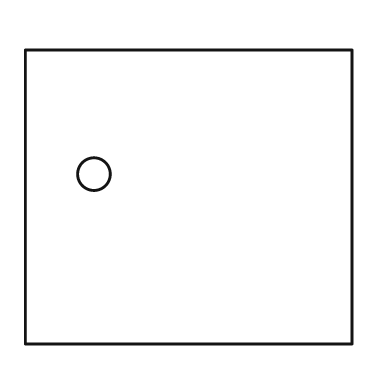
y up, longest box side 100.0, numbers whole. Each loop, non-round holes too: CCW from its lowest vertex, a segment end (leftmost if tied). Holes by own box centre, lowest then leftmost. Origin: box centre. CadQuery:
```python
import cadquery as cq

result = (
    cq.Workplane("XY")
    .moveTo(-50.0, -45.0)
    .lineTo(50.0, -45.0)
    .lineTo(50.0, 45.0)
    .lineTo(-50.0, 45.0)
    .close()
    .moveTo(-29.0, 7.0)
    .circle(5.0)
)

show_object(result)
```